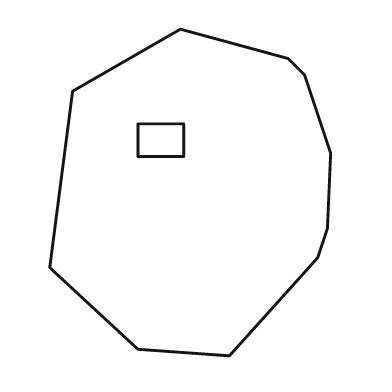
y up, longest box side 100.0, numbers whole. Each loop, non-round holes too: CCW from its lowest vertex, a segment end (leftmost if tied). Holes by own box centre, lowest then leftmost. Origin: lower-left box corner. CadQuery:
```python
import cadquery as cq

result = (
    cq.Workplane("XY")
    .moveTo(55.0, 0.0)
    .lineTo(82.0, 30.0)
    .lineTo(85.0, 39.0)
    .lineTo(86.0, 62.0)
    .lineTo(78.0, 86.0)
    .lineTo(73.0, 91.0)
    .lineTo(40.0, 100.0)
    .lineTo(7.0, 81.0)
    .lineTo(0.0, 27.0)
    .lineTo(27.0, 2.0)
    .close()
    .moveTo(27.0, 61.0)
    .lineTo(41.0, 61.0)
    .lineTo(41.0, 71.0)
    .lineTo(27.0, 71.0)
    .close()
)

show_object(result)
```